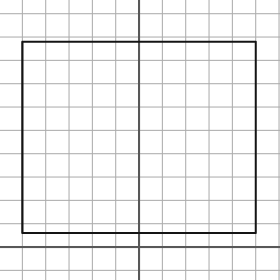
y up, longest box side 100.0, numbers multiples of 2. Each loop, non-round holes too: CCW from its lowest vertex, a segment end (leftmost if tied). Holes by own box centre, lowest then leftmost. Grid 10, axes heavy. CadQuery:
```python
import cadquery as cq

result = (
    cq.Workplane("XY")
    .moveTo(-50.0, 6.0)
    .lineTo(50.0, 6.0)
    .lineTo(50.0, 88.0)
    .lineTo(-50.0, 88.0)
    .close()
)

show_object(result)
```